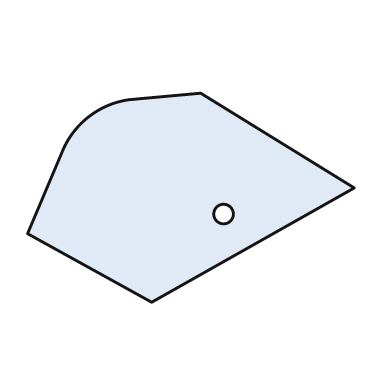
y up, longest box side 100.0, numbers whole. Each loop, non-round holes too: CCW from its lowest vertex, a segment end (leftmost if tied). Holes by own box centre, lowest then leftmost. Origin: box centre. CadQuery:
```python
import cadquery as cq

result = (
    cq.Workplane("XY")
    .moveTo(-12.0, -32.0)
    .lineTo(50.0, 3.0)
    .lineTo(3.0, 32.0)
    .lineTo(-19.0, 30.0)
    .threePointArc((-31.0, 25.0), (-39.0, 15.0))
    .lineTo(-50.0, -11.0)
    .close()
    .moveTo(10.0, -5.0)
    .circle(3.0)
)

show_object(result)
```